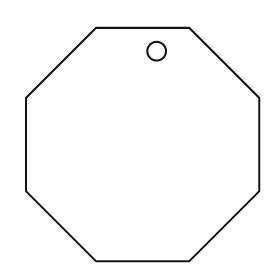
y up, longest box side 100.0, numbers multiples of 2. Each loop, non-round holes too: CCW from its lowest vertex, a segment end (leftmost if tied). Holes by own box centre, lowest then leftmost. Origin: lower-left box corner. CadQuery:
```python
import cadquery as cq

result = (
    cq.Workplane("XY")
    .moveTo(30.0, 0.0)
    .lineTo(70.0, 0.0)
    .lineTo(100.0, 30.0)
    .lineTo(100.0, 70.0)
    .lineTo(70.0, 100.0)
    .lineTo(30.0, 100.0)
    .lineTo(0.0, 70.0)
    .lineTo(0.0, 30.0)
    .close()
    .moveTo(56.0, 90.0)
    .circle(4.0)
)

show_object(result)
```